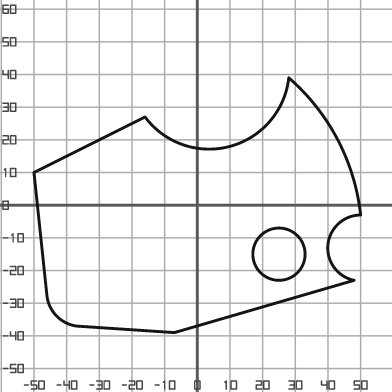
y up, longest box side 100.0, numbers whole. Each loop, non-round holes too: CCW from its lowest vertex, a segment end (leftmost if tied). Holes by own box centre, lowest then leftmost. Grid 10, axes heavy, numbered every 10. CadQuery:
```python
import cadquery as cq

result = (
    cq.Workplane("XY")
    .moveTo(-7.0, -39.0)
    .lineTo(48.0, -23.0)
    .threePointArc((40.0, -12.0), (50.0, -3.0))
    .threePointArc((43.0, 20.0), (28.0, 39.0))
    .threePointArc((10.0, 18.0), (-16.0, 27.0))
    .lineTo(-50.0, 10.0)
    .lineTo(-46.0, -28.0)
    .threePointArc((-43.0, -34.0), (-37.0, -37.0))
    .close()
    .moveTo(25.0, -15.0)
    .circle(8.0)
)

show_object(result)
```